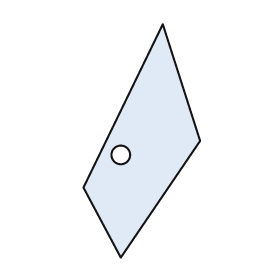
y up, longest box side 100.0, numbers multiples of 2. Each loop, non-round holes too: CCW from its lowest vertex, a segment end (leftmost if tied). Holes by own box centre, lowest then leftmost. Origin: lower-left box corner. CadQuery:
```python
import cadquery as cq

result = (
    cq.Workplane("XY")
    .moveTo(16.0, 0.0)
    .lineTo(50.0, 50.0)
    .lineTo(34.0, 100.0)
    .lineTo(0.0, 30.0)
    .close()
    .moveTo(16.0, 44.0)
    .circle(4.0)
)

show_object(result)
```